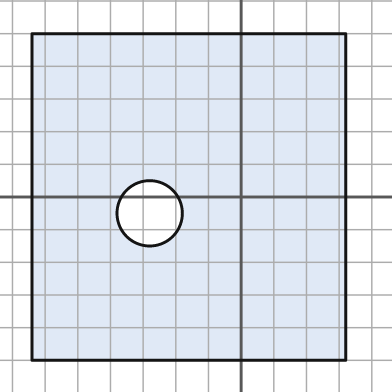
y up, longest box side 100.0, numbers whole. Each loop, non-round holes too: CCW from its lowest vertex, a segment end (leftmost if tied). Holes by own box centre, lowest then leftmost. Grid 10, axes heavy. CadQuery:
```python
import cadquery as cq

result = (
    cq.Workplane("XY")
    .moveTo(-64.0, -50.0)
    .lineTo(32.0, -50.0)
    .lineTo(32.0, 50.0)
    .lineTo(-64.0, 50.0)
    .close()
    .moveTo(-28.0, -5.0)
    .circle(10.0)
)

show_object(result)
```